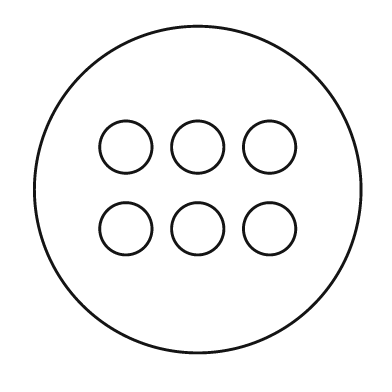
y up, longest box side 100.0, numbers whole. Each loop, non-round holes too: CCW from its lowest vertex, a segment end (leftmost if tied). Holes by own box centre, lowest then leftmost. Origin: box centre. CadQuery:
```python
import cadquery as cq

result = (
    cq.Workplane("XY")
    .moveTo(0.0, 0.0)
    .circle(50.0)
    .moveTo(-22.0, -12.0)
    .circle(8.0)
    .moveTo(0.0, -12.0)
    .circle(8.0)
    .moveTo(22.0, -12.0)
    .circle(8.0)
    .moveTo(-22.0, 13.0)
    .circle(8.0)
    .moveTo(0.0, 13.0)
    .circle(8.0)
    .moveTo(22.0, 13.0)
    .circle(8.0)
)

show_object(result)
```